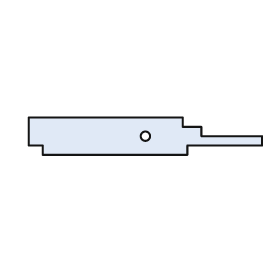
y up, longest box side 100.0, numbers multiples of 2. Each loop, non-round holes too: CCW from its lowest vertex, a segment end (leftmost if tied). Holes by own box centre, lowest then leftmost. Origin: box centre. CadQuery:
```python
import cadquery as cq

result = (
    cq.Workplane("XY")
    .moveTo(-44.0, -8.0)
    .lineTo(18.0, -8.0)
    .lineTo(18.0, -4.0)
    .lineTo(50.0, -4.0)
    .lineTo(50.0, 0.0)
    .lineTo(24.0, 0.0)
    .lineTo(24.0, 4.0)
    .lineTo(16.0, 4.0)
    .lineTo(16.0, 8.0)
    .lineTo(-50.0, 8.0)
    .lineTo(-50.0, -4.0)
    .lineTo(-44.0, -4.0)
    .close()
    .moveTo(0.0, 0.0)
    .circle(2.0)
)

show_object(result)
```